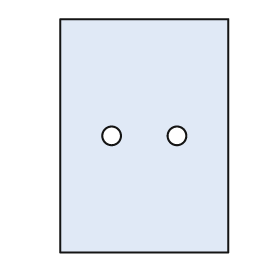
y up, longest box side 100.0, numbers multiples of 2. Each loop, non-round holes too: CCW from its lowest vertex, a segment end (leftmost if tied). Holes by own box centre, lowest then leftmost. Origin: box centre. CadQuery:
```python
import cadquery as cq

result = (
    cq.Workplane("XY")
    .moveTo(-36.0, -50.0)
    .lineTo(36.0, -50.0)
    .lineTo(36.0, 50.0)
    .lineTo(-36.0, 50.0)
    .close()
    .moveTo(-14.0, 0.0)
    .circle(4.0)
    .moveTo(14.0, 0.0)
    .circle(4.0)
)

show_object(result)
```